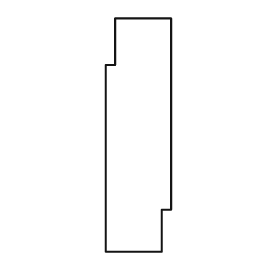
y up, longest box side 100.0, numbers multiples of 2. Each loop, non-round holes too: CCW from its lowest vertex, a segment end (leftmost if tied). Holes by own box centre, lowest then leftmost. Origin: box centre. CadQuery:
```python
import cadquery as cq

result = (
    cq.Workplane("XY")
    .moveTo(-14.0, -50.0)
    .lineTo(10.0, -50.0)
    .lineTo(10.0, -32.0)
    .lineTo(14.0, -32.0)
    .lineTo(14.0, 50.0)
    .lineTo(-10.0, 50.0)
    .lineTo(-10.0, 30.0)
    .lineTo(-14.0, 30.0)
    .close()
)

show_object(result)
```